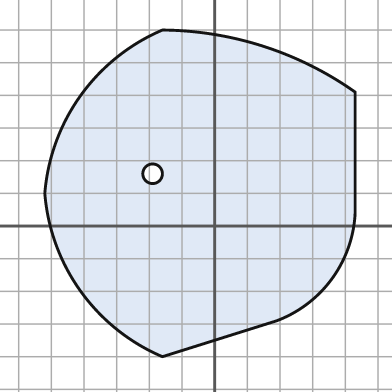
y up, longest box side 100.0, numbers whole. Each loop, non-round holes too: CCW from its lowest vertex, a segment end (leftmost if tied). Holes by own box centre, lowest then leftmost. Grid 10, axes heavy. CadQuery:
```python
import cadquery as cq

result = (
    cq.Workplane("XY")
    .moveTo(-16.0, -40.0)
    .lineTo(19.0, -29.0)
    .threePointArc((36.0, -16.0), (43.0, 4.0))
    .lineTo(43.0, 41.0)
    .threePointArc((15.0, 55.0), (-16.0, 60.0))
    .threePointArc((-41.0, 40.0), (-52.0, 10.0))
    .threePointArc((-41.0, -20.0), (-16.0, -40.0))
    .close()
    .moveTo(-19.0, 16.0)
    .circle(3.0)
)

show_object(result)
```